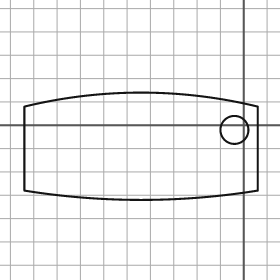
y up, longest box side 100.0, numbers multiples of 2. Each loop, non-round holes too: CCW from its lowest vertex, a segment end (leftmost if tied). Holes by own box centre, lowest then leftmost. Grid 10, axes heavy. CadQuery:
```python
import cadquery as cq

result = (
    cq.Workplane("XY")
    .moveTo(-94.0, -28.0)
    .threePointArc((-44.0, -32.0), (6.0, -28.0))
    .lineTo(6.0, 8.0)
    .threePointArc((-44.0, 14.0), (-94.0, 8.0))
    .close()
    .moveTo(-4.0, -2.0)
    .circle(6.0)
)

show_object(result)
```